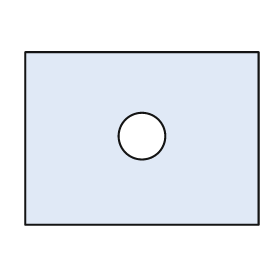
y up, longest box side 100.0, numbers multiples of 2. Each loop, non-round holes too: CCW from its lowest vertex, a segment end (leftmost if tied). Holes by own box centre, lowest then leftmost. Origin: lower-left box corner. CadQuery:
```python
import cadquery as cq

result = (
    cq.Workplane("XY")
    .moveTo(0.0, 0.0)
    .lineTo(100.0, 0.0)
    .lineTo(100.0, 74.0)
    .lineTo(0.0, 74.0)
    .close()
    .moveTo(50.0, 38.0)
    .circle(10.0)
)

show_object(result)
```